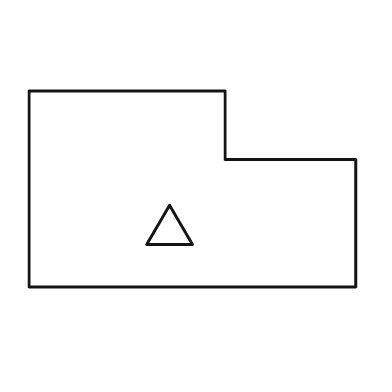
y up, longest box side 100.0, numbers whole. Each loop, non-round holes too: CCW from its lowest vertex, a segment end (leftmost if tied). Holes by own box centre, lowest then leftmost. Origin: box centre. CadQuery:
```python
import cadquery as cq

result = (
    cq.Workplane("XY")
    .moveTo(-50.0, -30.0)
    .lineTo(50.0, -30.0)
    .lineTo(50.0, 9.0)
    .lineTo(10.0, 9.0)
    .lineTo(10.0, 30.0)
    .lineTo(-50.0, 30.0)
    .close()
    .moveTo(-14.0, -17.0)
    .lineTo(0.0, -17.0)
    .lineTo(-7.0, -5.0)
    .close()
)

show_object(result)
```